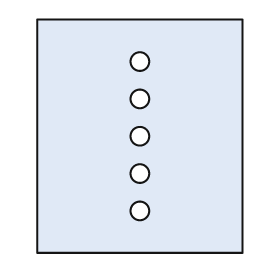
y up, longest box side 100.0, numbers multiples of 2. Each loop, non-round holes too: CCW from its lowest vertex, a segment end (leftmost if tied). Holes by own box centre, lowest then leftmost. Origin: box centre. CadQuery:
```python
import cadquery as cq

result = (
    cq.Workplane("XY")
    .moveTo(-44.0, -50.0)
    .lineTo(44.0, -50.0)
    .lineTo(44.0, 50.0)
    .lineTo(-44.0, 50.0)
    .close()
    .moveTo(0.0, -32.0)
    .circle(4.0)
    .moveTo(0.0, -16.0)
    .circle(4.0)
    .moveTo(0.0, 0.0)
    .circle(4.0)
    .moveTo(0.0, 16.0)
    .circle(4.0)
    .moveTo(0.0, 32.0)
    .circle(4.0)
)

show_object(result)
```